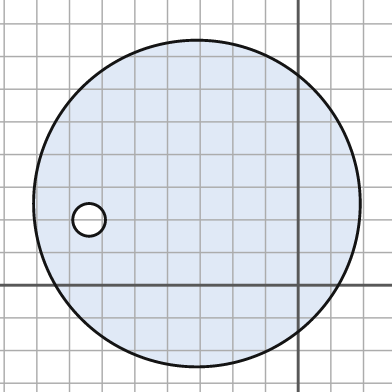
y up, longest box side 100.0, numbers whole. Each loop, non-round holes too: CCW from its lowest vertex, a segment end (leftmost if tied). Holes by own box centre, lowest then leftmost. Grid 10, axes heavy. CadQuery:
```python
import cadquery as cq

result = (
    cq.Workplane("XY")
    .moveTo(-31.0, 25.0)
    .circle(50.0)
    .moveTo(-64.0, 20.0)
    .circle(5.0)
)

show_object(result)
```